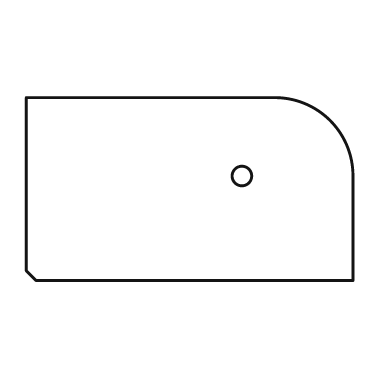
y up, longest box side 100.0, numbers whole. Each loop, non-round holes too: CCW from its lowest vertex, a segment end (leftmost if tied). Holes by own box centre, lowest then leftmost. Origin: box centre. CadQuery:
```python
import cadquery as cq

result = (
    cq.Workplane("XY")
    .moveTo(-47.0, -28.0)
    .lineTo(50.0, -28.0)
    .lineTo(50.0, 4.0)
    .threePointArc((43.0, 21.0), (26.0, 28.0))
    .lineTo(-50.0, 28.0)
    .lineTo(-50.0, -25.0)
    .close()
    .moveTo(16.0, 4.0)
    .circle(3.0)
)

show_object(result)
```